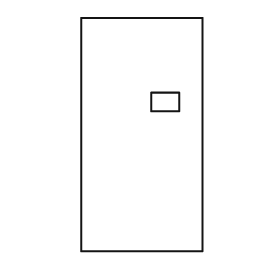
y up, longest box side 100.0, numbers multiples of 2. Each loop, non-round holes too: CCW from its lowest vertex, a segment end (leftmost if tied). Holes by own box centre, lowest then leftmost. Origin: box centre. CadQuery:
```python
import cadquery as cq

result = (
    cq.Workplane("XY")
    .moveTo(-26.0, -50.0)
    .lineTo(26.0, -50.0)
    .lineTo(26.0, 50.0)
    .lineTo(-26.0, 50.0)
    .close()
    .moveTo(4.0, 10.0)
    .lineTo(16.0, 10.0)
    .lineTo(16.0, 18.0)
    .lineTo(4.0, 18.0)
    .close()
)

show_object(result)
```